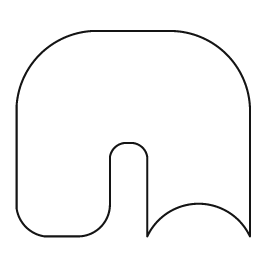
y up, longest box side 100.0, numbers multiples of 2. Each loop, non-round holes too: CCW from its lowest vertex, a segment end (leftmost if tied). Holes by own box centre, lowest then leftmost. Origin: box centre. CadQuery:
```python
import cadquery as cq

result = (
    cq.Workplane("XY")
    .moveTo(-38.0, -44.0)
    .lineTo(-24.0, -44.0)
    .threePointArc((-14.0, -40.0), (-10.0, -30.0))
    .lineTo(-10.0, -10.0)
    .threePointArc((-8.0, -6.0), (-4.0, -4.0))
    .lineTo(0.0, -4.0)
    .threePointArc((4.0, -6.0), (6.0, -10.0))
    .lineTo(6.0, -44.0)
    .threePointArc((28.0, -30.0), (50.0, -44.0))
    .lineTo(50.0, 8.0)
    .threePointArc((40.0, 34.0), (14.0, 44.0))
    .lineTo(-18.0, 44.0)
    .threePointArc((-40.0, 34.0), (-50.0, 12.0))
    .lineTo(-50.0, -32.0)
    .threePointArc((-46.0, -40.0), (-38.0, -44.0))
    .close()
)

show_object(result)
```